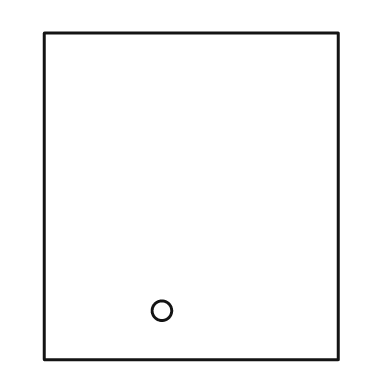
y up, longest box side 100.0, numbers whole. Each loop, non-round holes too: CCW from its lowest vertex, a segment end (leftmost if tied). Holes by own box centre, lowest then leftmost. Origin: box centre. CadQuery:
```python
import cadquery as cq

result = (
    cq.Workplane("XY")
    .moveTo(-45.0, -50.0)
    .lineTo(45.0, -50.0)
    .lineTo(45.0, 50.0)
    .lineTo(-45.0, 50.0)
    .close()
    .moveTo(-9.0, -35.0)
    .circle(3.0)
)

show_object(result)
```